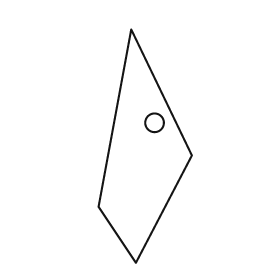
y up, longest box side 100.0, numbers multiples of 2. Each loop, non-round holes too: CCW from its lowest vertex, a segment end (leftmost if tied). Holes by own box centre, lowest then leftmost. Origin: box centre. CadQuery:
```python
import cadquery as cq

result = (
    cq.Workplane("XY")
    .moveTo(-4.0, -50.0)
    .lineTo(20.0, -4.0)
    .lineTo(-6.0, 50.0)
    .lineTo(-20.0, -26.0)
    .close()
    .moveTo(4.0, 10.0)
    .circle(4.0)
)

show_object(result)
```